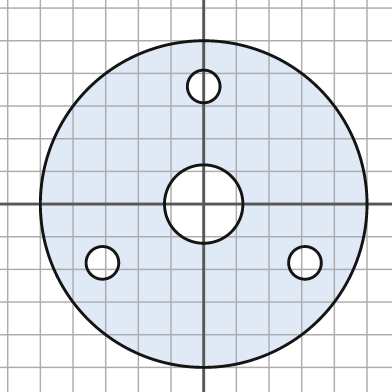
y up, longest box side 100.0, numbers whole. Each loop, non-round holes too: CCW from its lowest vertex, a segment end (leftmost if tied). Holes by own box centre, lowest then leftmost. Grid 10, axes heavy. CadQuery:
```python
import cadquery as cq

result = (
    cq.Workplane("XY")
    .moveTo(0.0, 0.0)
    .circle(50.0)
    .moveTo(-31.0, -18.0)
    .circle(5.0)
    .moveTo(31.0, -18.0)
    .circle(5.0)
    .moveTo(0.0, 0.0)
    .circle(12.0)
    .moveTo(0.0, 36.0)
    .circle(5.0)
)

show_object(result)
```